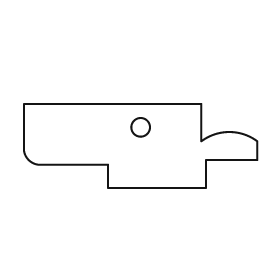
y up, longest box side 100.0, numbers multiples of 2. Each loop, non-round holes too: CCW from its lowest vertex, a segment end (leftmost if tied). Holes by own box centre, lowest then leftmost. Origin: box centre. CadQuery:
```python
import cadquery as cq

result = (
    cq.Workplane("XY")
    .moveTo(-14.0, -18.0)
    .lineTo(28.0, -18.0)
    .lineTo(28.0, -6.0)
    .lineTo(50.0, -6.0)
    .lineTo(50.0, 2.0)
    .threePointArc((38.0, 6.0), (26.0, 2.0))
    .lineTo(26.0, 18.0)
    .lineTo(-50.0, 18.0)
    .lineTo(-50.0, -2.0)
    .threePointArc((-48.0, -6.0), (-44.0, -8.0))
    .lineTo(-14.0, -8.0)
    .close()
    .moveTo(0.0, 8.0)
    .circle(4.0)
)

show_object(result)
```